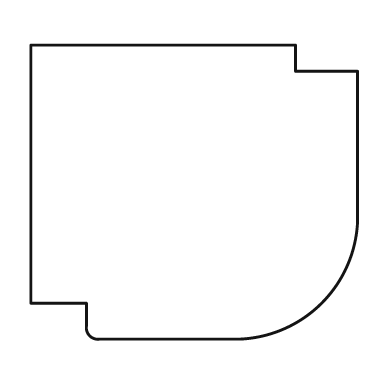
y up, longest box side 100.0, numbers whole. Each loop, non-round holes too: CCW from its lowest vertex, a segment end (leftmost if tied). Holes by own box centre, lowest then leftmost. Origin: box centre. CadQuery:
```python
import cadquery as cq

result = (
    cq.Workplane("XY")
    .moveTo(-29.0, -45.0)
    .lineTo(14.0, -45.0)
    .threePointArc((39.0, -34.0), (50.0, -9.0))
    .lineTo(50.0, 37.0)
    .lineTo(31.0, 37.0)
    .lineTo(31.0, 45.0)
    .lineTo(-50.0, 45.0)
    .lineTo(-50.0, -34.0)
    .lineTo(-33.0, -34.0)
    .lineTo(-33.0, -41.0)
    .threePointArc((-32.0, -44.0), (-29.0, -45.0))
    .close()
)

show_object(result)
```